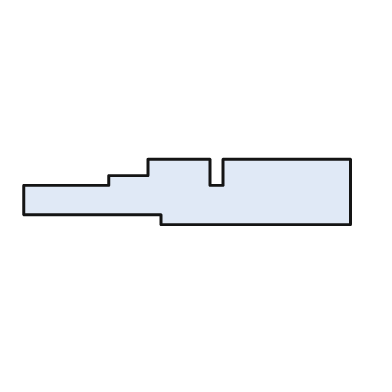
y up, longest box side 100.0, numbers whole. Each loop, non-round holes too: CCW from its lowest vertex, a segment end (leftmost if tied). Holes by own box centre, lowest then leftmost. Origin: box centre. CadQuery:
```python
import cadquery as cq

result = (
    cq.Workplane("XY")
    .moveTo(-8.0, -10.0)
    .lineTo(50.0, -10.0)
    .lineTo(50.0, 10.0)
    .lineTo(11.0, 10.0)
    .lineTo(11.0, 2.0)
    .lineTo(7.0, 2.0)
    .lineTo(7.0, 10.0)
    .lineTo(-12.0, 10.0)
    .lineTo(-12.0, 5.0)
    .lineTo(-24.0, 5.0)
    .lineTo(-24.0, 2.0)
    .lineTo(-50.0, 2.0)
    .lineTo(-50.0, -7.0)
    .lineTo(-8.0, -7.0)
    .close()
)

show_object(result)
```